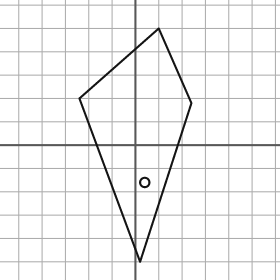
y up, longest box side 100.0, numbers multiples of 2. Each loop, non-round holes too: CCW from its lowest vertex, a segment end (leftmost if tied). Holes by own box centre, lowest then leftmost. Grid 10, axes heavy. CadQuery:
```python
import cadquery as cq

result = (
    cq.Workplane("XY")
    .moveTo(2.0, -50.0)
    .lineTo(24.0, 18.0)
    .lineTo(10.0, 50.0)
    .lineTo(-24.0, 20.0)
    .close()
    .moveTo(4.0, -16.0)
    .circle(2.0)
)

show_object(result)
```